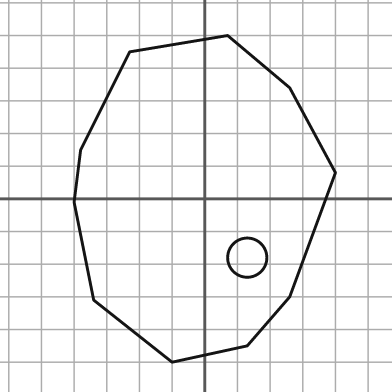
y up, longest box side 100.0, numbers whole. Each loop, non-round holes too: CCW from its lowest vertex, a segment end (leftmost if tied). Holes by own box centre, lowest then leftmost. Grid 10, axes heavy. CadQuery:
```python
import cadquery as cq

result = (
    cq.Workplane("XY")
    .moveTo(-10.0, -50.0)
    .lineTo(13.0, -45.0)
    .lineTo(26.0, -30.0)
    .lineTo(40.0, 8.0)
    .lineTo(26.0, 34.0)
    .lineTo(7.0, 50.0)
    .lineTo(-23.0, 45.0)
    .lineTo(-38.0, 15.0)
    .lineTo(-40.0, -1.0)
    .lineTo(-34.0, -31.0)
    .close()
    .moveTo(13.0, -18.0)
    .circle(6.0)
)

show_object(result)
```